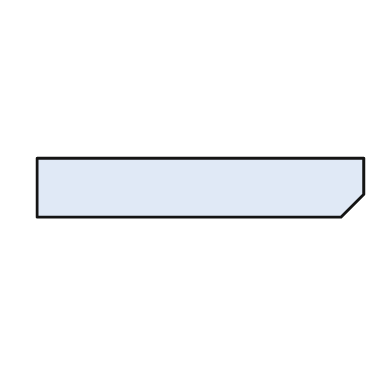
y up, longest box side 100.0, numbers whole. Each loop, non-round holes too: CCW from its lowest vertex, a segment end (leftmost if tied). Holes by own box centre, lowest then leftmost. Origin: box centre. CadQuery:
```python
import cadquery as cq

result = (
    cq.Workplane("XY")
    .moveTo(-50.0, -9.0)
    .lineTo(43.0, -9.0)
    .lineTo(50.0, -2.0)
    .lineTo(50.0, 9.0)
    .lineTo(-50.0, 9.0)
    .close()
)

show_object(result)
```